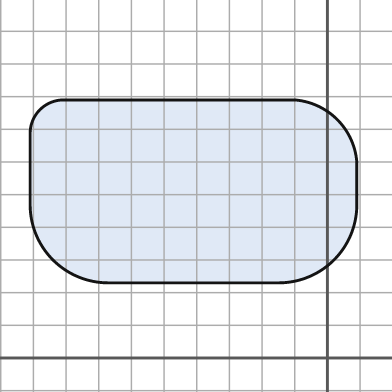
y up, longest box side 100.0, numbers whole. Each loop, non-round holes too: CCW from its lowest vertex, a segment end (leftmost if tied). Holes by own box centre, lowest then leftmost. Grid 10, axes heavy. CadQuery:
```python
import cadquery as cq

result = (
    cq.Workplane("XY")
    .moveTo(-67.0, 23.0)
    .lineTo(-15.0, 23.0)
    .threePointArc((2.0, 30.0), (9.0, 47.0))
    .lineTo(9.0, 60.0)
    .threePointArc((3.0, 73.0), (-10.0, 79.0))
    .lineTo(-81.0, 79.0)
    .threePointArc((-88.0, 76.0), (-91.0, 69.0))
    .lineTo(-91.0, 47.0)
    .threePointArc((-84.0, 30.0), (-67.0, 23.0))
    .close()
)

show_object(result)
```